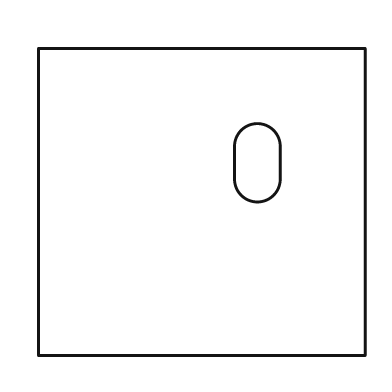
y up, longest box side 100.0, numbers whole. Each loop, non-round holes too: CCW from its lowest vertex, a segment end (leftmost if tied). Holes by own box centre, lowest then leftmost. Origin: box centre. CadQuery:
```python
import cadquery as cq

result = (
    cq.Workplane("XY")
    .moveTo(-50.0, -47.0)
    .lineTo(50.0, -47.0)
    .lineTo(50.0, 47.0)
    .lineTo(-50.0, 47.0)
    .close()
    .moveTo(10.0, 7.0)
    .threePointArc((17.0, 0.0), (24.0, 7.0))
    .lineTo(24.0, 17.0)
    .threePointArc((17.0, 24.0), (10.0, 17.0))
    .close()
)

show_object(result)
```